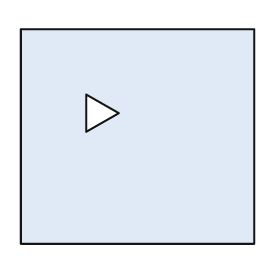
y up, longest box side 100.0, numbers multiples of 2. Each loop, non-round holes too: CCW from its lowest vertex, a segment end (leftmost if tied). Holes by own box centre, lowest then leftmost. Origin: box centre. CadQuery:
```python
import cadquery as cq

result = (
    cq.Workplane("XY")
    .moveTo(-50.0, -46.0)
    .lineTo(50.0, -46.0)
    .lineTo(50.0, 46.0)
    .lineTo(-50.0, 46.0)
    .close()
    .moveTo(-22.0, 2.0)
    .lineTo(-8.0, 10.0)
    .lineTo(-22.0, 18.0)
    .close()
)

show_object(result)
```